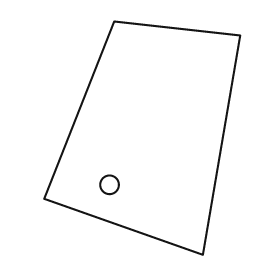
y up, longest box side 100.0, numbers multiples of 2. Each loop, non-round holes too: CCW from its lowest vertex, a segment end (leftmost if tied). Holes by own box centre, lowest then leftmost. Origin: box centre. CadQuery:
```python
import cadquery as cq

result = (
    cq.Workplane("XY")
    .moveTo(26.0, -50.0)
    .lineTo(42.0, 44.0)
    .lineTo(-12.0, 50.0)
    .lineTo(-42.0, -26.0)
    .close()
    .moveTo(-14.0, -20.0)
    .circle(4.0)
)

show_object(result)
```